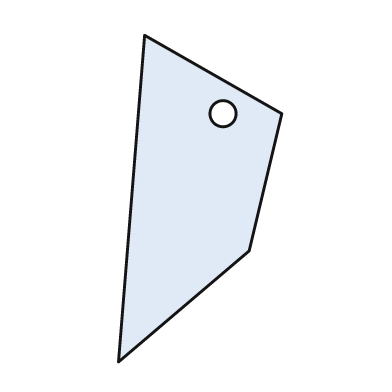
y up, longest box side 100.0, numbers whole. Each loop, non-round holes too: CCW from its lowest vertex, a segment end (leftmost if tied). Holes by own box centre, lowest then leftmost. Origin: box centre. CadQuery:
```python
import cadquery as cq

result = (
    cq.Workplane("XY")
    .moveTo(-25.0, -50.0)
    .lineTo(15.0, -16.0)
    .lineTo(25.0, 26.0)
    .lineTo(-17.0, 50.0)
    .close()
    .moveTo(7.0, 26.0)
    .circle(4.0)
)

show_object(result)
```